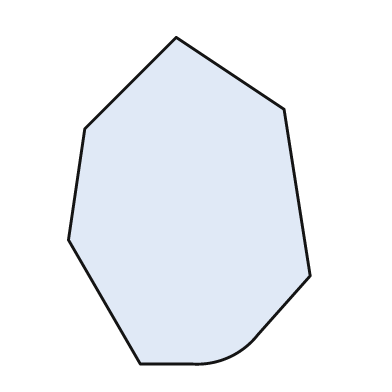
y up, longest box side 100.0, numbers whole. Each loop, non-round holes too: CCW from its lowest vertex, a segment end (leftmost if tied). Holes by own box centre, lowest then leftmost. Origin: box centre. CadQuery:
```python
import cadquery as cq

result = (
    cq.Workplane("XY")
    .moveTo(-15.0, -50.0)
    .lineTo(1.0, -50.0)
    .threePointArc((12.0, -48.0), (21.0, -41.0))
    .lineTo(37.0, -23.0)
    .lineTo(29.0, 28.0)
    .lineTo(-4.0, 50.0)
    .lineTo(-32.0, 22.0)
    .lineTo(-37.0, -12.0)
    .close()
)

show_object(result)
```